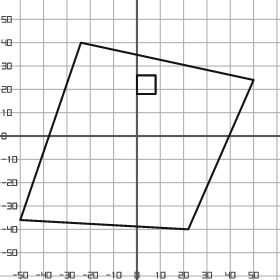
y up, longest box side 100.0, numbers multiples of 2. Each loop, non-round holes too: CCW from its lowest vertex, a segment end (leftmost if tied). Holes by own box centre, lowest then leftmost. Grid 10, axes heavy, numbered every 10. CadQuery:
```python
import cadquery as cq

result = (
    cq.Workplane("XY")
    .moveTo(22.0, -40.0)
    .lineTo(50.0, 24.0)
    .lineTo(-24.0, 40.0)
    .lineTo(-50.0, -36.0)
    .close()
    .moveTo(0.0, 18.0)
    .lineTo(8.0, 18.0)
    .lineTo(8.0, 26.0)
    .lineTo(0.0, 26.0)
    .close()
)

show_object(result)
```